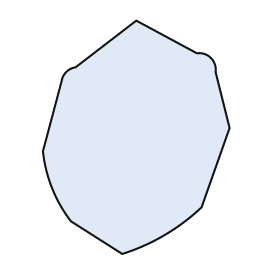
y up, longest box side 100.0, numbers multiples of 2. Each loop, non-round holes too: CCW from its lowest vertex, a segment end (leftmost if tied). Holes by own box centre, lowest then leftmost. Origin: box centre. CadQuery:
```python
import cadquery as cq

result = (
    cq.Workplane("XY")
    .moveTo(-6.0, -50.0)
    .threePointArc((12.0, -42.0), (28.0, -30.0))
    .lineTo(40.0, 4.0)
    .lineTo(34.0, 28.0)
    .threePointArc((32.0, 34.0), (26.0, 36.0))
    .lineTo(0.0, 50.0)
    .lineTo(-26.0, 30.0)
    .threePointArc((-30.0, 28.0), (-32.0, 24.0))
    .lineTo(-40.0, -6.0)
    .threePointArc((-36.0, -22.0), (-28.0, -36.0))
    .close()
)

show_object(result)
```